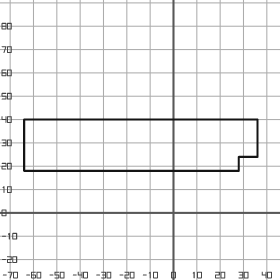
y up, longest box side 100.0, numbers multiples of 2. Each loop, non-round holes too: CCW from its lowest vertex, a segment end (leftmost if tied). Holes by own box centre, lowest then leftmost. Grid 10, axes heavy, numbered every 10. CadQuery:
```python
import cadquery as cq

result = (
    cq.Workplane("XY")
    .moveTo(-64.0, 18.0)
    .lineTo(28.0, 18.0)
    .lineTo(28.0, 24.0)
    .lineTo(36.0, 24.0)
    .lineTo(36.0, 40.0)
    .lineTo(-64.0, 40.0)
    .close()
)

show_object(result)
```